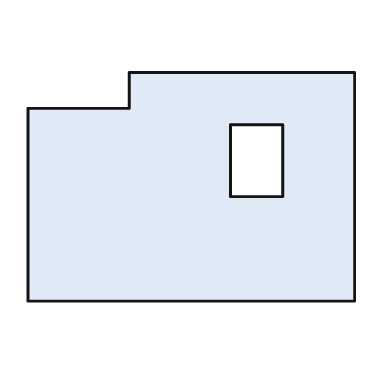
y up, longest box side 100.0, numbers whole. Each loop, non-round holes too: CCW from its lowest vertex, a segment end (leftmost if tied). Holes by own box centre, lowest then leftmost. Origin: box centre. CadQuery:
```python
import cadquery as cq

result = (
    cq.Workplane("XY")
    .moveTo(-50.0, -35.0)
    .lineTo(50.0, -35.0)
    .lineTo(50.0, 35.0)
    .lineTo(-19.0, 35.0)
    .lineTo(-19.0, 24.0)
    .lineTo(-50.0, 24.0)
    .close()
    .moveTo(12.0, -3.0)
    .lineTo(28.0, -3.0)
    .lineTo(28.0, 19.0)
    .lineTo(12.0, 19.0)
    .close()
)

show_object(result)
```